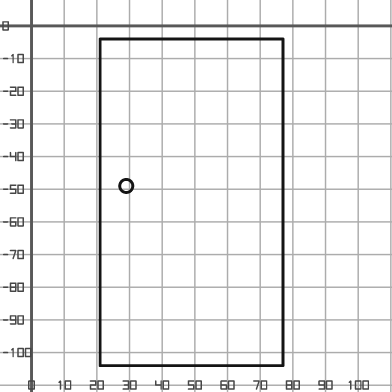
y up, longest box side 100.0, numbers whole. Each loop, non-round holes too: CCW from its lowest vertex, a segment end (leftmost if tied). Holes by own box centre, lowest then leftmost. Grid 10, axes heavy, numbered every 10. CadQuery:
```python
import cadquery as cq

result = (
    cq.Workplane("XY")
    .moveTo(21.0, -104.0)
    .lineTo(77.0, -104.0)
    .lineTo(77.0, -4.0)
    .lineTo(21.0, -4.0)
    .close()
    .moveTo(29.0, -49.0)
    .circle(2.0)
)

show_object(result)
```